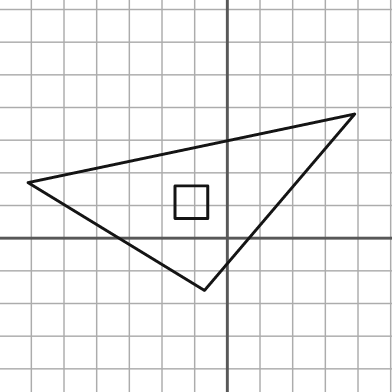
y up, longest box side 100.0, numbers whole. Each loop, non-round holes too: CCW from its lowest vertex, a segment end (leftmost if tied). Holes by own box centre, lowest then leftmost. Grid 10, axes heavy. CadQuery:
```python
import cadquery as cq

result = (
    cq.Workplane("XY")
    .moveTo(-7.0, -16.0)
    .lineTo(39.0, 38.0)
    .lineTo(-61.0, 17.0)
    .close()
    .moveTo(-16.0, 6.0)
    .lineTo(-6.0, 6.0)
    .lineTo(-6.0, 16.0)
    .lineTo(-16.0, 16.0)
    .close()
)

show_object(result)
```